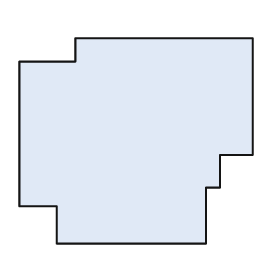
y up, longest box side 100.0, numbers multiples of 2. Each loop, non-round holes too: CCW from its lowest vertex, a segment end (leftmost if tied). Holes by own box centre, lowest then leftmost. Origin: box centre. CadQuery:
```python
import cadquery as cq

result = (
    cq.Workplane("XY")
    .moveTo(-34.0, -44.0)
    .lineTo(30.0, -44.0)
    .lineTo(30.0, -20.0)
    .lineTo(36.0, -20.0)
    .lineTo(36.0, -6.0)
    .lineTo(50.0, -6.0)
    .lineTo(50.0, 44.0)
    .lineTo(-26.0, 44.0)
    .lineTo(-26.0, 34.0)
    .lineTo(-50.0, 34.0)
    .lineTo(-50.0, -28.0)
    .lineTo(-34.0, -28.0)
    .close()
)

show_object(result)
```